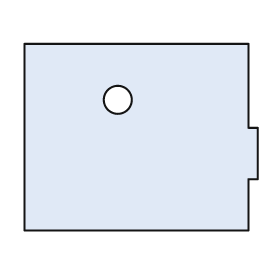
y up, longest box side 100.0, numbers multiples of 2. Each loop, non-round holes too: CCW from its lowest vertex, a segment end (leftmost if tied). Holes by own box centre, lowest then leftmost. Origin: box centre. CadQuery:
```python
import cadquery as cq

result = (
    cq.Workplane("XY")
    .moveTo(-50.0, -40.0)
    .lineTo(46.0, -40.0)
    .lineTo(46.0, -18.0)
    .lineTo(50.0, -18.0)
    .lineTo(50.0, 4.0)
    .lineTo(46.0, 4.0)
    .lineTo(46.0, 40.0)
    .lineTo(-50.0, 40.0)
    .close()
    .moveTo(-10.0, 16.0)
    .circle(6.0)
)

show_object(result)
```